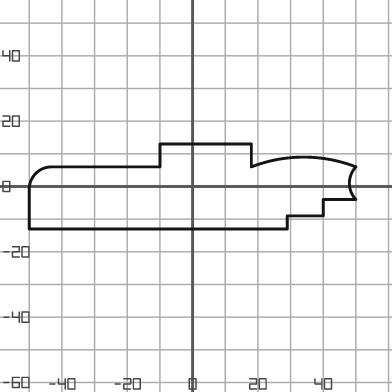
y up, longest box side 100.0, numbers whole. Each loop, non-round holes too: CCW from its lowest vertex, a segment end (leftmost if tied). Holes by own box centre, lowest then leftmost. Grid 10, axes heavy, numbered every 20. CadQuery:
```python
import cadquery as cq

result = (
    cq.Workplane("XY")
    .moveTo(-50.0, -13.0)
    .lineTo(29.0, -13.0)
    .lineTo(29.0, -9.0)
    .lineTo(40.0, -9.0)
    .lineTo(40.0, -4.0)
    .lineTo(50.0, -4.0)
    .threePointArc((48.0, 1.0), (50.0, 6.0))
    .threePointArc((34.0, 9.0), (18.0, 6.0))
    .lineTo(18.0, 13.0)
    .lineTo(-10.0, 13.0)
    .lineTo(-10.0, 6.0)
    .lineTo(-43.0, 6.0)
    .threePointArc((-48.0, 4.0), (-50.0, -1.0))
    .close()
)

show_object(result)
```